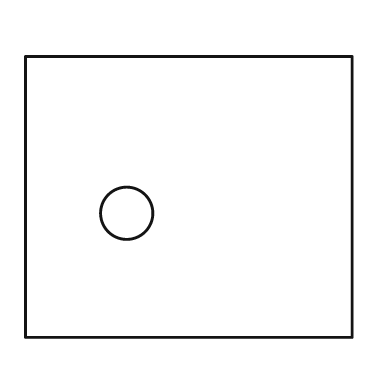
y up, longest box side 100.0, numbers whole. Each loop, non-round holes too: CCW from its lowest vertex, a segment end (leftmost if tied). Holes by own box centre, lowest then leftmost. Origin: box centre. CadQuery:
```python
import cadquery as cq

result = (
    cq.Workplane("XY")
    .moveTo(-50.0, -43.0)
    .lineTo(50.0, -43.0)
    .lineTo(50.0, 43.0)
    .lineTo(-50.0, 43.0)
    .close()
    .moveTo(-19.0, -5.0)
    .circle(8.0)
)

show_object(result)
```